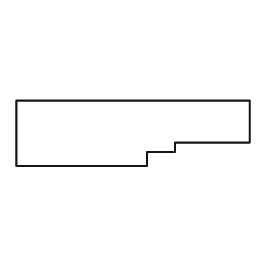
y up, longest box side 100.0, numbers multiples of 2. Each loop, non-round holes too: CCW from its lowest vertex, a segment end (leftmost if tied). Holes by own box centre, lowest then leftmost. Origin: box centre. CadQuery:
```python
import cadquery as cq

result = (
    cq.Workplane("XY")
    .moveTo(-50.0, -14.0)
    .lineTo(6.0, -14.0)
    .lineTo(6.0, -8.0)
    .lineTo(18.0, -8.0)
    .lineTo(18.0, -4.0)
    .lineTo(50.0, -4.0)
    .lineTo(50.0, 14.0)
    .lineTo(-50.0, 14.0)
    .close()
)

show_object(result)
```